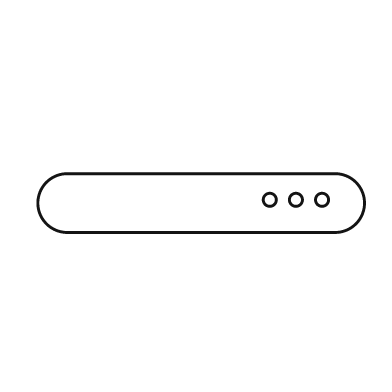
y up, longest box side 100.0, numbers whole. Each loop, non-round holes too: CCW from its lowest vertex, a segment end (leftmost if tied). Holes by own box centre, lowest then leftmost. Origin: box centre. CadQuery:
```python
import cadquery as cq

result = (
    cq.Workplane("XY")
    .moveTo(-41.0, -9.0)
    .lineTo(41.0, -9.0)
    .threePointArc((50.0, 0.0), (41.0, 9.0))
    .lineTo(-41.0, 9.0)
    .threePointArc((-50.0, 0.0), (-41.0, -9.0))
    .close()
    .moveTo(21.0, 1.0)
    .circle(2.0)
    .moveTo(29.0, 1.0)
    .circle(2.0)
    .moveTo(37.0, 1.0)
    .circle(2.0)
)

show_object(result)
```